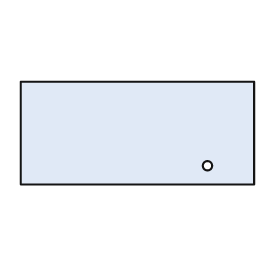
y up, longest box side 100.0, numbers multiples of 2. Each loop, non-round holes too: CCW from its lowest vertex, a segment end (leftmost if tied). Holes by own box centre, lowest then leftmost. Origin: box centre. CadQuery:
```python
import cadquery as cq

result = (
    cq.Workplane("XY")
    .moveTo(-50.0, -22.0)
    .lineTo(50.0, -22.0)
    .lineTo(50.0, 22.0)
    .lineTo(-50.0, 22.0)
    .close()
    .moveTo(30.0, -14.0)
    .circle(2.0)
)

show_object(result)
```